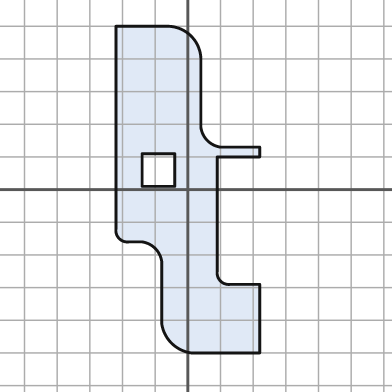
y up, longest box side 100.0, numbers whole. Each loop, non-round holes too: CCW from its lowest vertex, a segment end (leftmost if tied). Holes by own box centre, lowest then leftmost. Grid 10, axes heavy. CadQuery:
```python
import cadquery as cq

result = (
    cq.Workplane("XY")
    .moveTo(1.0, -50.0)
    .lineTo(22.0, -50.0)
    .lineTo(22.0, -29.0)
    .lineTo(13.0, -29.0)
    .threePointArc((10.0, -28.0), (9.0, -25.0))
    .lineTo(9.0, 10.0)
    .lineTo(22.0, 10.0)
    .lineTo(22.0, 13.0)
    .lineTo(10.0, 13.0)
    .threePointArc((6.0, 15.0), (4.0, 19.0))
    .lineTo(4.0, 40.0)
    .threePointArc((1.0, 47.0), (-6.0, 50.0))
    .lineTo(-22.0, 50.0)
    .lineTo(-22.0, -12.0)
    .threePointArc((-21.0, -15.0), (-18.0, -16.0))
    .lineTo(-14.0, -16.0)
    .threePointArc((-10.0, -18.0), (-8.0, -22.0))
    .lineTo(-8.0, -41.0)
    .threePointArc((-5.0, -47.0), (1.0, -50.0))
    .close()
    .moveTo(-14.0, 1.0)
    .lineTo(-4.0, 1.0)
    .lineTo(-4.0, 11.0)
    .lineTo(-14.0, 11.0)
    .close()
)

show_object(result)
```